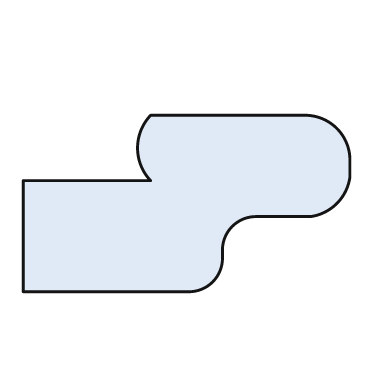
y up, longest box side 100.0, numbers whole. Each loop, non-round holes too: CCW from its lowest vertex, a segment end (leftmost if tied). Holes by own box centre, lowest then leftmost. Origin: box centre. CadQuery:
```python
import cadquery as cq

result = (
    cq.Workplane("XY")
    .moveTo(-50.0, -27.0)
    .lineTo(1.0, -27.0)
    .threePointArc((8.0, -24.0), (11.0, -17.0))
    .lineTo(11.0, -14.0)
    .threePointArc((14.0, -7.0), (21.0, -4.0))
    .lineTo(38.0, -4.0)
    .threePointArc((46.0, 0.0), (50.0, 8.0))
    .lineTo(50.0, 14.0)
    .threePointArc((46.0, 23.0), (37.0, 27.0))
    .lineTo(-11.0, 27.0)
    .threePointArc((-15.0, 17.0), (-11.0, 7.0))
    .lineTo(-50.0, 7.0)
    .close()
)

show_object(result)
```